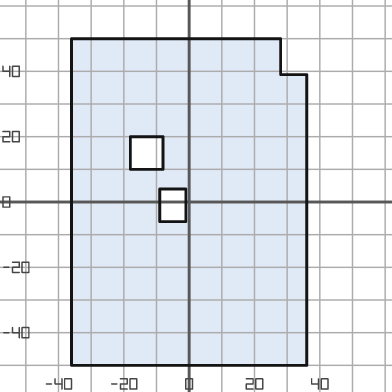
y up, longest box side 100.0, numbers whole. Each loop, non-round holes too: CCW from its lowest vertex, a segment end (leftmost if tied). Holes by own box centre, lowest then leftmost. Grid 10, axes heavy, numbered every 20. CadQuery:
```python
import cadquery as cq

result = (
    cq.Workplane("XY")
    .moveTo(-36.0, -50.0)
    .lineTo(36.0, -50.0)
    .lineTo(36.0, 39.0)
    .lineTo(28.0, 39.0)
    .lineTo(28.0, 50.0)
    .lineTo(-36.0, 50.0)
    .close()
    .moveTo(-9.0, -6.0)
    .lineTo(-1.0, -6.0)
    .lineTo(-1.0, 4.0)
    .lineTo(-9.0, 4.0)
    .close()
    .moveTo(-18.0, 10.0)
    .lineTo(-8.0, 10.0)
    .lineTo(-8.0, 20.0)
    .lineTo(-18.0, 20.0)
    .close()
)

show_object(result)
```